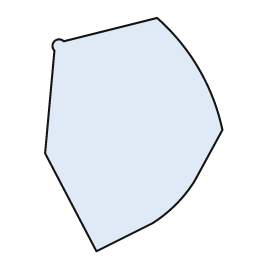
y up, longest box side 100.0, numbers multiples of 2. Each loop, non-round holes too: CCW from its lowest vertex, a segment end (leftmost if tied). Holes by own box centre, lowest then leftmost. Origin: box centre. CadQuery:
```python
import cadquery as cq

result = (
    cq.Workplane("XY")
    .moveTo(-16.0, -50.0)
    .lineTo(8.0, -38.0)
    .threePointArc((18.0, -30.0), (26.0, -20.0))
    .lineTo(38.0, 2.0)
    .threePointArc((28.0, 28.0), (10.0, 50.0))
    .lineTo(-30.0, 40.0)
    .threePointArc((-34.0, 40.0), (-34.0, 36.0))
    .lineTo(-38.0, -8.0)
    .close()
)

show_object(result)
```